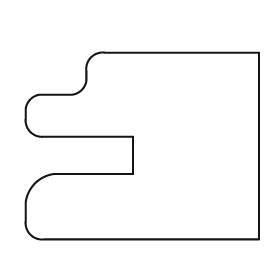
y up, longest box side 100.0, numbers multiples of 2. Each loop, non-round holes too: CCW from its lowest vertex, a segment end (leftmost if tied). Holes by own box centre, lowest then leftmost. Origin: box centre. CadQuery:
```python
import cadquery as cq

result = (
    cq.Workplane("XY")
    .moveTo(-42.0, -40.0)
    .lineTo(50.0, -40.0)
    .lineTo(50.0, 40.0)
    .lineTo(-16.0, 40.0)
    .threePointArc((-22.0, 38.0), (-24.0, 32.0))
    .lineTo(-24.0, 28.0)
    .threePointArc((-26.0, 24.0), (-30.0, 22.0))
    .lineTo(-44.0, 22.0)
    .threePointArc((-48.0, 20.0), (-50.0, 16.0))
    .lineTo(-50.0, 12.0)
    .threePointArc((-48.0, 6.0), (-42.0, 4.0))
    .lineTo(-4.0, 4.0)
    .lineTo(-4.0, -12.0)
    .lineTo(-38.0, -12.0)
    .threePointArc((-46.0, -16.0), (-50.0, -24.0))
    .lineTo(-50.0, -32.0)
    .threePointArc((-48.0, -38.0), (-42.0, -40.0))
    .close()
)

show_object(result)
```